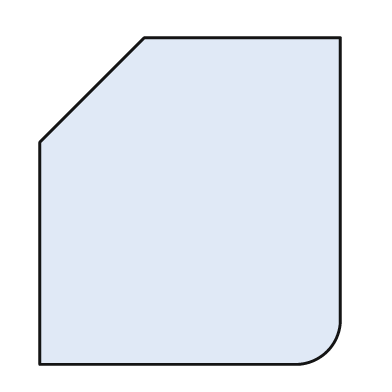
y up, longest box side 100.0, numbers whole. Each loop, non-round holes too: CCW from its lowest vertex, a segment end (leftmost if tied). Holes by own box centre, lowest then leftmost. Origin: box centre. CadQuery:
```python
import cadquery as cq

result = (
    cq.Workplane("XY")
    .moveTo(-46.0, -50.0)
    .lineTo(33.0, -50.0)
    .threePointArc((42.0, -46.0), (46.0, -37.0))
    .lineTo(46.0, 50.0)
    .lineTo(-14.0, 50.0)
    .lineTo(-46.0, 18.0)
    .close()
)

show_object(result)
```